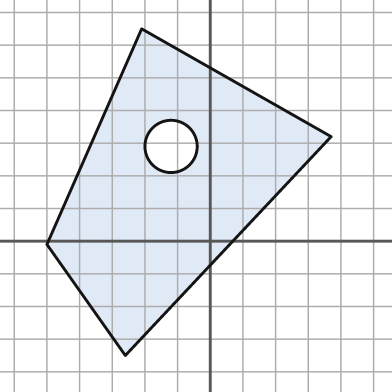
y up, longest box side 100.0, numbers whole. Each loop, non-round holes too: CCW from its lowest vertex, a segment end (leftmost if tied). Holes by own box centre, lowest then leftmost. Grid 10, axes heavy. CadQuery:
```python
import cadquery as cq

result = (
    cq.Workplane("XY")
    .moveTo(-26.0, -35.0)
    .lineTo(37.0, 32.0)
    .lineTo(-21.0, 65.0)
    .lineTo(-50.0, -1.0)
    .close()
    .moveTo(-12.0, 29.0)
    .circle(8.0)
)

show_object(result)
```